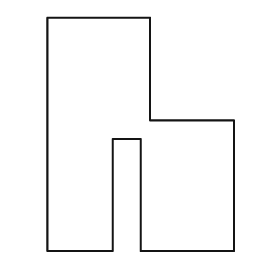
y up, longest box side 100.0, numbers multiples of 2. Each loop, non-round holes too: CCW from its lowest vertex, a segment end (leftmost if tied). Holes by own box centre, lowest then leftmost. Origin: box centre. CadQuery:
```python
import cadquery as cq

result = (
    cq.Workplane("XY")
    .moveTo(-40.0, -50.0)
    .lineTo(-12.0, -50.0)
    .lineTo(-12.0, -2.0)
    .lineTo(0.0, -2.0)
    .lineTo(0.0, -50.0)
    .lineTo(40.0, -50.0)
    .lineTo(40.0, 6.0)
    .lineTo(4.0, 6.0)
    .lineTo(4.0, 50.0)
    .lineTo(-40.0, 50.0)
    .close()
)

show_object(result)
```